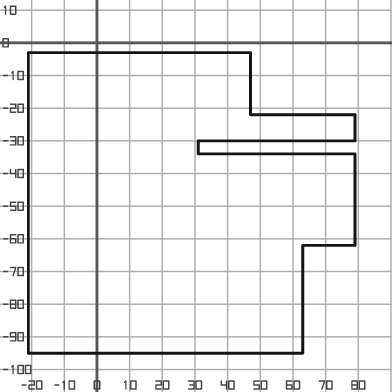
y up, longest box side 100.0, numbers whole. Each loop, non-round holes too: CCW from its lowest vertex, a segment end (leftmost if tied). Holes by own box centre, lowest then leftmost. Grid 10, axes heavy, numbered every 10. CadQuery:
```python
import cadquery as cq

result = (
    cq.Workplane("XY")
    .moveTo(-21.0, -95.0)
    .lineTo(63.0, -95.0)
    .lineTo(63.0, -62.0)
    .lineTo(79.0, -62.0)
    .lineTo(79.0, -34.0)
    .lineTo(31.0, -34.0)
    .lineTo(31.0, -30.0)
    .lineTo(79.0, -30.0)
    .lineTo(79.0, -22.0)
    .lineTo(47.0, -22.0)
    .lineTo(47.0, -3.0)
    .lineTo(-21.0, -3.0)
    .close()
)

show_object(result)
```